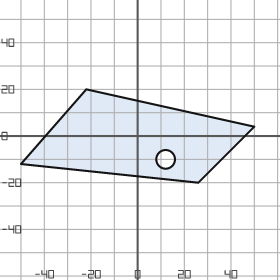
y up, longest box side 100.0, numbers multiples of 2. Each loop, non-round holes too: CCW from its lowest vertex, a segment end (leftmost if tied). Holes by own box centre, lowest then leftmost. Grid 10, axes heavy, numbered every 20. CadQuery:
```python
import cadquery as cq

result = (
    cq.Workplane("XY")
    .moveTo(26.0, -20.0)
    .lineTo(50.0, 4.0)
    .lineTo(-22.0, 20.0)
    .lineTo(-50.0, -12.0)
    .close()
    .moveTo(12.0, -10.0)
    .circle(4.0)
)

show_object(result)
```